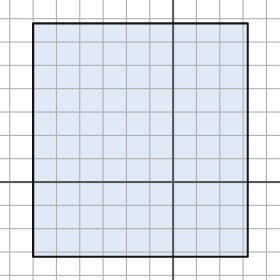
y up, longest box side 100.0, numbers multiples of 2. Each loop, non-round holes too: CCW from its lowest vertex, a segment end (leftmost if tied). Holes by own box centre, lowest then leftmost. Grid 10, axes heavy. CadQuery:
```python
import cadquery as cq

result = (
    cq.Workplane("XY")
    .moveTo(-60.0, -32.0)
    .lineTo(32.0, -32.0)
    .lineTo(32.0, 68.0)
    .lineTo(-60.0, 68.0)
    .close()
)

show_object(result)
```